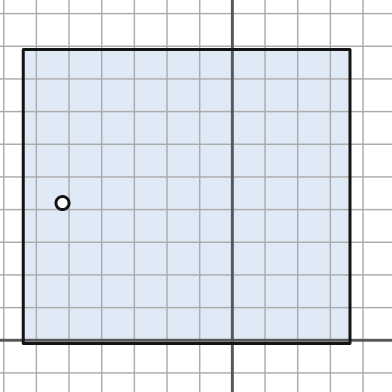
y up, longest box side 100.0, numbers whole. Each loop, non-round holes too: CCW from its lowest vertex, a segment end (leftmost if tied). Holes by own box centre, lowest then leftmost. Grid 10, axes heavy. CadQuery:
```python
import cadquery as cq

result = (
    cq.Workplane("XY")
    .moveTo(-64.0, -1.0)
    .lineTo(36.0, -1.0)
    .lineTo(36.0, 89.0)
    .lineTo(-64.0, 89.0)
    .close()
    .moveTo(-52.0, 42.0)
    .circle(2.0)
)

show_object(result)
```